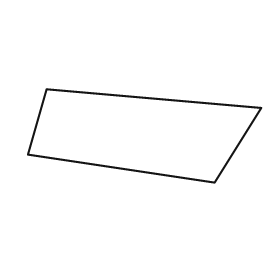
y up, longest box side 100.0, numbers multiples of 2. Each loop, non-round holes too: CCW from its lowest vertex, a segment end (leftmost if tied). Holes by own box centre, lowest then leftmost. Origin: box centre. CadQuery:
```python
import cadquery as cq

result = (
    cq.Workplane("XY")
    .moveTo(30.0, -20.0)
    .lineTo(50.0, 12.0)
    .lineTo(-42.0, 20.0)
    .lineTo(-50.0, -8.0)
    .close()
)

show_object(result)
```